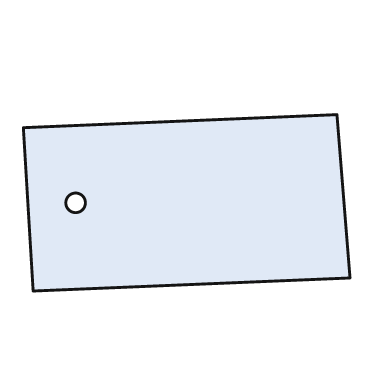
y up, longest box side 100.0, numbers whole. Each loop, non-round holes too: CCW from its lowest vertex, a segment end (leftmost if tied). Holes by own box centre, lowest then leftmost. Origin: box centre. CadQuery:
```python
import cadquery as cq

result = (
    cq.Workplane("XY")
    .moveTo(-47.0, -27.0)
    .lineTo(50.0, -23.0)
    .lineTo(46.0, 27.0)
    .lineTo(-50.0, 23.0)
    .close()
    .moveTo(-34.0, 0.0)
    .circle(3.0)
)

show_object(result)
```